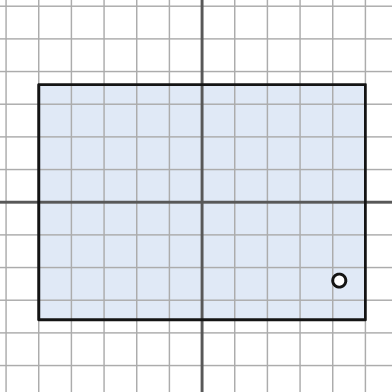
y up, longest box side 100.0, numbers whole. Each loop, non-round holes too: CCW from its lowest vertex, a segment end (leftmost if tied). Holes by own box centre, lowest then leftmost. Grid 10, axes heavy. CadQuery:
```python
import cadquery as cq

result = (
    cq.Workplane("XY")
    .moveTo(-50.0, -36.0)
    .lineTo(50.0, -36.0)
    .lineTo(50.0, 36.0)
    .lineTo(-50.0, 36.0)
    .close()
    .moveTo(42.0, -24.0)
    .circle(2.0)
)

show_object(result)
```